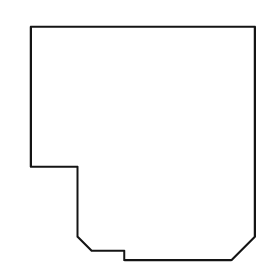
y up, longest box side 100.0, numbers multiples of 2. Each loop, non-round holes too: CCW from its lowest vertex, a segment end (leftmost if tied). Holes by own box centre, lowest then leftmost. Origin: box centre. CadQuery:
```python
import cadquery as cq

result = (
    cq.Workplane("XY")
    .moveTo(-8.0, -50.0)
    .lineTo(38.0, -50.0)
    .lineTo(48.0, -40.0)
    .lineTo(48.0, 50.0)
    .lineTo(-48.0, 50.0)
    .lineTo(-48.0, -10.0)
    .lineTo(-28.0, -10.0)
    .lineTo(-28.0, -40.0)
    .lineTo(-22.0, -46.0)
    .lineTo(-8.0, -46.0)
    .close()
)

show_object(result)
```